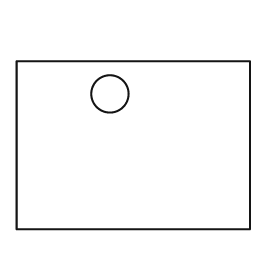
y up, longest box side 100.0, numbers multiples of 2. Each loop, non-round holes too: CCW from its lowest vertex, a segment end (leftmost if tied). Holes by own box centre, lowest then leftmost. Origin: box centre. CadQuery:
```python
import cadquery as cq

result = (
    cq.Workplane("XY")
    .moveTo(-50.0, -36.0)
    .lineTo(50.0, -36.0)
    .lineTo(50.0, 36.0)
    .lineTo(-50.0, 36.0)
    .close()
    .moveTo(-10.0, 22.0)
    .circle(8.0)
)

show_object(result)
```